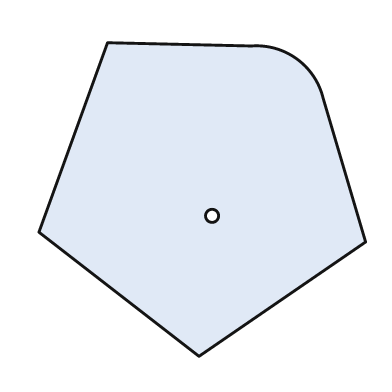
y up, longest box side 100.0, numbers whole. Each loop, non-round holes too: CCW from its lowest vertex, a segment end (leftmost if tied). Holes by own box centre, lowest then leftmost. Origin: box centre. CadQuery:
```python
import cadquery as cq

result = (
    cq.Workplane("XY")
    .moveTo(-1.0, -48.0)
    .lineTo(50.0, -13.0)
    .lineTo(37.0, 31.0)
    .threePointArc((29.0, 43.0), (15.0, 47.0))
    .lineTo(-29.0, 48.0)
    .lineTo(-50.0, -10.0)
    .close()
    .moveTo(3.0, -5.0)
    .circle(2.0)
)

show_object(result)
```